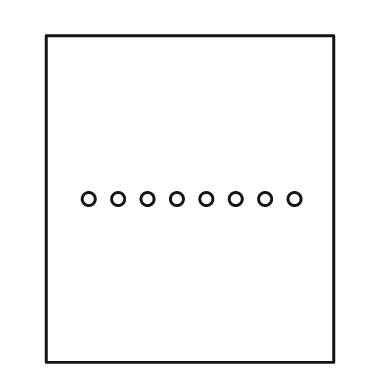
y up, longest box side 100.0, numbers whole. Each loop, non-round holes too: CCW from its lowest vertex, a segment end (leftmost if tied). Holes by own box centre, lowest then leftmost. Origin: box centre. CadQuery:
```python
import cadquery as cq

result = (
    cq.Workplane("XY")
    .moveTo(-44.0, -50.0)
    .lineTo(44.0, -50.0)
    .lineTo(44.0, 50.0)
    .lineTo(-44.0, 50.0)
    .close()
    .moveTo(-31.0, 0.0)
    .circle(2.0)
    .moveTo(-22.0, 0.0)
    .circle(2.0)
    .moveTo(-13.0, 0.0)
    .circle(2.0)
    .moveTo(-4.0, 0.0)
    .circle(2.0)
    .moveTo(5.0, 0.0)
    .circle(2.0)
    .moveTo(14.0, 0.0)
    .circle(2.0)
    .moveTo(23.0, 0.0)
    .circle(2.0)
    .moveTo(32.0, 0.0)
    .circle(2.0)
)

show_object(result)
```